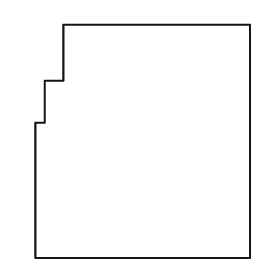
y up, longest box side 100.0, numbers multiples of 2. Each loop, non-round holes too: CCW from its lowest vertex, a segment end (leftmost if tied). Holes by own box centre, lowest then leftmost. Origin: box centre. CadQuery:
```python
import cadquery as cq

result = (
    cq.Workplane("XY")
    .moveTo(-46.0, -50.0)
    .lineTo(46.0, -50.0)
    .lineTo(46.0, 50.0)
    .lineTo(-34.0, 50.0)
    .lineTo(-34.0, 26.0)
    .lineTo(-42.0, 26.0)
    .lineTo(-42.0, 8.0)
    .lineTo(-46.0, 8.0)
    .close()
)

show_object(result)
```